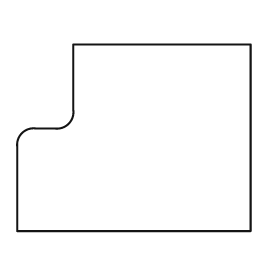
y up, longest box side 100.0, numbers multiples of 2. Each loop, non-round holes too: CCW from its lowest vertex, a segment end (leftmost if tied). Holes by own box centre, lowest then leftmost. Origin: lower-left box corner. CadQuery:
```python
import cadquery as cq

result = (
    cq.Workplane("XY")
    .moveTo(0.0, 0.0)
    .lineTo(100.0, 0.0)
    .lineTo(100.0, 80.0)
    .lineTo(24.0, 80.0)
    .lineTo(24.0, 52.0)
    .threePointArc((22.0, 46.0), (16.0, 44.0))
    .lineTo(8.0, 44.0)
    .threePointArc((2.0, 42.0), (0.0, 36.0))
    .close()
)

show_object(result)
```